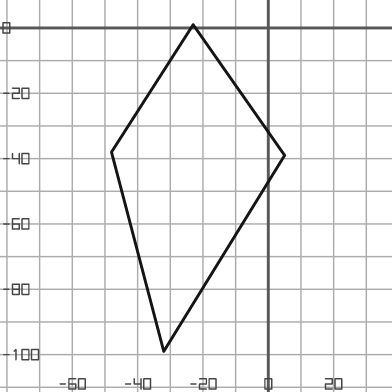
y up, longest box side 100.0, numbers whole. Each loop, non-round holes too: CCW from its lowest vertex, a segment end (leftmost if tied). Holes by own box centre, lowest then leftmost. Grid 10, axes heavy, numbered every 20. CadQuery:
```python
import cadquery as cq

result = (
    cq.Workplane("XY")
    .moveTo(-32.0, -99.0)
    .lineTo(5.0, -39.0)
    .lineTo(-23.0, 1.0)
    .lineTo(-48.0, -38.0)
    .close()
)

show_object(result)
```